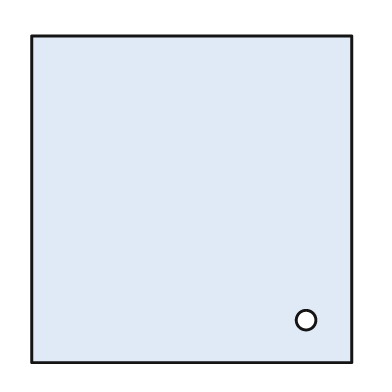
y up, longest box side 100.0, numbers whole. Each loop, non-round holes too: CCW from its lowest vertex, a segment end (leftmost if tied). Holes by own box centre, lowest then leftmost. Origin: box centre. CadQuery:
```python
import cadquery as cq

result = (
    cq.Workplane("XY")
    .moveTo(-49.0, -50.0)
    .lineTo(49.0, -50.0)
    .lineTo(49.0, 50.0)
    .lineTo(-49.0, 50.0)
    .close()
    .moveTo(35.0, -37.0)
    .circle(3.0)
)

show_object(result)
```